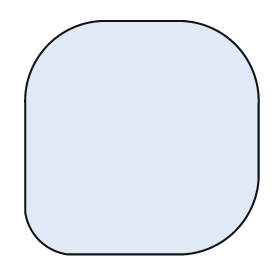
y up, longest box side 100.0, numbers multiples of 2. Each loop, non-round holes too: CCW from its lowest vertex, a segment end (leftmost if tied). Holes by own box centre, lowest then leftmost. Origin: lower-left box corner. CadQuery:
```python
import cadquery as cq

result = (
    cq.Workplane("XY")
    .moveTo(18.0, 0.0)
    .lineTo(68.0, 0.0)
    .threePointArc((90.0, 10.0), (100.0, 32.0))
    .lineTo(100.0, 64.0)
    .threePointArc((90.0, 90.0), (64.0, 100.0))
    .lineTo(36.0, 100.0)
    .threePointArc((10.0, 90.0), (0.0, 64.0))
    .lineTo(0.0, 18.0)
    .threePointArc((6.0, 6.0), (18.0, 0.0))
    .close()
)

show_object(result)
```